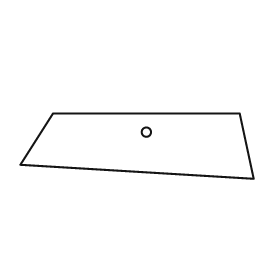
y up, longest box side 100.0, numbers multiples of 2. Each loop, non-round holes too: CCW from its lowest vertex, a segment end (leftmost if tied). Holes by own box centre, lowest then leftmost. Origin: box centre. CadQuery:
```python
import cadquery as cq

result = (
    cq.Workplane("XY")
    .moveTo(50.0, -14.0)
    .lineTo(44.0, 14.0)
    .lineTo(-36.0, 14.0)
    .lineTo(-50.0, -8.0)
    .close()
    .moveTo(4.0, 6.0)
    .circle(2.0)
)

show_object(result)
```